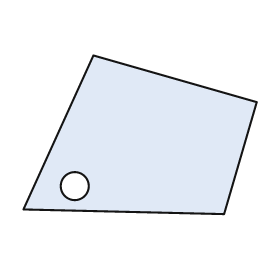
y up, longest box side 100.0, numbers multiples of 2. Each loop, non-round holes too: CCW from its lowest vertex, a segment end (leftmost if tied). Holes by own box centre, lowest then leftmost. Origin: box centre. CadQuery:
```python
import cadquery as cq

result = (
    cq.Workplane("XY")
    .moveTo(36.0, -34.0)
    .lineTo(50.0, 14.0)
    .lineTo(-20.0, 34.0)
    .lineTo(-50.0, -32.0)
    .close()
    .moveTo(-28.0, -22.0)
    .circle(6.0)
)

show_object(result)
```